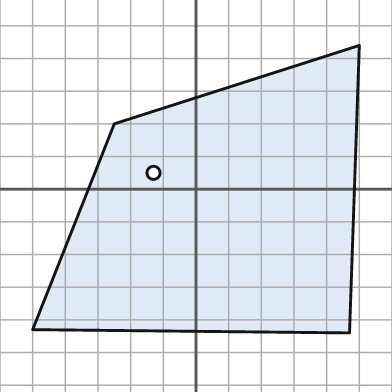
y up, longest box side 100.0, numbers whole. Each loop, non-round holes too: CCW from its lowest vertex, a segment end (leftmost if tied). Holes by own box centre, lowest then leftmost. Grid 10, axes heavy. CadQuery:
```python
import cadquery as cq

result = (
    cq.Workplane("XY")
    .moveTo(47.0, -44.0)
    .lineTo(50.0, 44.0)
    .lineTo(-25.0, 20.0)
    .lineTo(-50.0, -43.0)
    .close()
    .moveTo(-13.0, 5.0)
    .circle(2.0)
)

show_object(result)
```